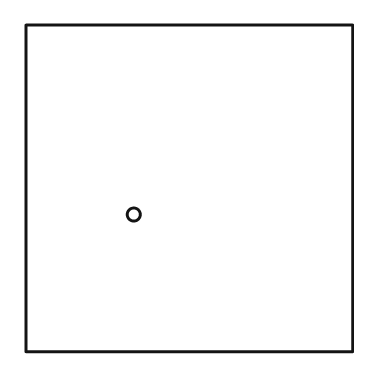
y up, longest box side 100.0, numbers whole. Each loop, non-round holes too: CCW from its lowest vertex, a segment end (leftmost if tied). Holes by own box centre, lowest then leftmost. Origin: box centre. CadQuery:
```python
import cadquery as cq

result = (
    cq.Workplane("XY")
    .moveTo(-50.0, -50.0)
    .lineTo(50.0, -50.0)
    .lineTo(50.0, 50.0)
    .lineTo(-50.0, 50.0)
    .close()
    .moveTo(-17.0, -8.0)
    .circle(2.0)
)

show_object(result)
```